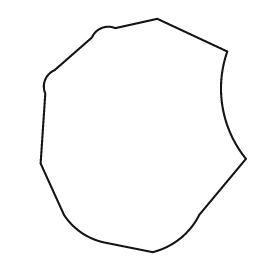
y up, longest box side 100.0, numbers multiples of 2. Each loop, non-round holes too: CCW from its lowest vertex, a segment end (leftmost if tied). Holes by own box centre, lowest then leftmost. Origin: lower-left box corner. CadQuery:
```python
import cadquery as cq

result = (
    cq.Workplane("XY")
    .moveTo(48.0, 0.0)
    .threePointArc((60.0, 6.0), (68.0, 16.0))
    .lineTo(88.0, 40.0)
    .threePointArc((78.0, 62.0), (80.0, 86.0))
    .lineTo(50.0, 100.0)
    .lineTo(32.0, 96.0)
    .threePointArc((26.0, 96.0), (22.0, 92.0))
    .lineTo(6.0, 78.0)
    .threePointArc((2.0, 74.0), (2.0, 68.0))
    .lineTo(0.0, 38.0)
    .lineTo(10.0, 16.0)
    .threePointArc((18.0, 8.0), (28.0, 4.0))
    .close()
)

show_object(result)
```